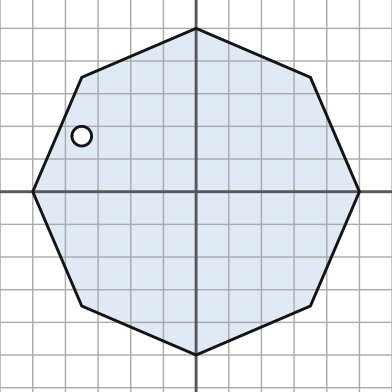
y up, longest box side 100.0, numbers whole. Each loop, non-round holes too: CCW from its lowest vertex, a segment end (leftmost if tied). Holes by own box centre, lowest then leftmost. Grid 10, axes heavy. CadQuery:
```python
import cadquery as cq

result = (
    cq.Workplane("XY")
    .moveTo(0.0, -50.0)
    .lineTo(35.0, -35.0)
    .lineTo(50.0, 0.0)
    .lineTo(35.0, 35.0)
    .lineTo(0.0, 50.0)
    .lineTo(-35.0, 35.0)
    .lineTo(-50.0, 0.0)
    .lineTo(-35.0, -35.0)
    .close()
    .moveTo(-35.0, 17.0)
    .circle(3.0)
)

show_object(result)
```